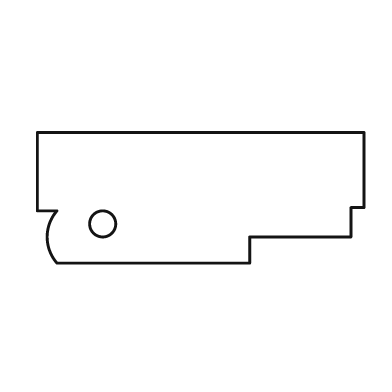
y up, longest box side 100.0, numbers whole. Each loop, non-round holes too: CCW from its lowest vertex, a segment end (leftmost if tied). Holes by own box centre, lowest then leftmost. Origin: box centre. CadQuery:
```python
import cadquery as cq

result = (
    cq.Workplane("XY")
    .moveTo(-44.0, -20.0)
    .lineTo(15.0, -20.0)
    .lineTo(15.0, -12.0)
    .lineTo(46.0, -12.0)
    .lineTo(46.0, -3.0)
    .lineTo(50.0, -3.0)
    .lineTo(50.0, 20.0)
    .lineTo(-50.0, 20.0)
    .lineTo(-50.0, -4.0)
    .lineTo(-44.0, -4.0)
    .threePointArc((-47.0, -12.0), (-44.0, -20.0))
    .close()
    .moveTo(-30.0, -8.0)
    .circle(4.0)
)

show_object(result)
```